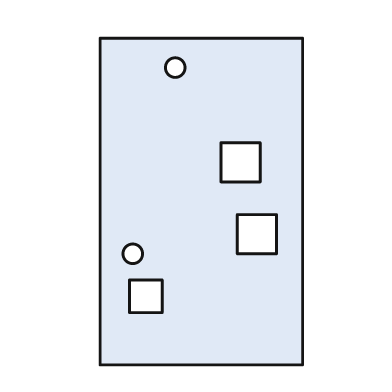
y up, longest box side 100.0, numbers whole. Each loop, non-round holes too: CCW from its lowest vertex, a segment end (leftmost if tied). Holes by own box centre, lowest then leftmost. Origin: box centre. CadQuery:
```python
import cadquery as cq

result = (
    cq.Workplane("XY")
    .moveTo(-31.0, -50.0)
    .lineTo(31.0, -50.0)
    .lineTo(31.0, 50.0)
    .lineTo(-31.0, 50.0)
    .close()
    .moveTo(-22.0, -34.0)
    .lineTo(-12.0, -34.0)
    .lineTo(-12.0, -24.0)
    .lineTo(-22.0, -24.0)
    .close()
    .moveTo(-21.0, -16.0)
    .circle(3.0)
    .moveTo(11.0, -16.0)
    .lineTo(23.0, -16.0)
    .lineTo(23.0, -4.0)
    .lineTo(11.0, -4.0)
    .close()
    .moveTo(6.0, 6.0)
    .lineTo(18.0, 6.0)
    .lineTo(18.0, 18.0)
    .lineTo(6.0, 18.0)
    .close()
    .moveTo(-8.0, 41.0)
    .circle(3.0)
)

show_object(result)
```